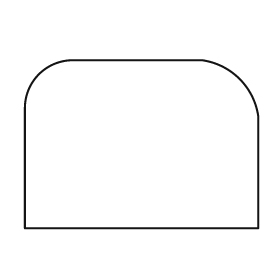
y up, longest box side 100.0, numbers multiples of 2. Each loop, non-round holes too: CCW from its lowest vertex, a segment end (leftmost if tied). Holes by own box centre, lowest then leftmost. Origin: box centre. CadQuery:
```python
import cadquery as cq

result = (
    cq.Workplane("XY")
    .moveTo(-50.0, -36.0)
    .lineTo(50.0, -36.0)
    .lineTo(50.0, 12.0)
    .threePointArc((42.0, 28.0), (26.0, 36.0))
    .lineTo(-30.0, 36.0)
    .threePointArc((-44.0, 30.0), (-50.0, 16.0))
    .close()
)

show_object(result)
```